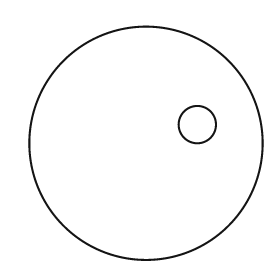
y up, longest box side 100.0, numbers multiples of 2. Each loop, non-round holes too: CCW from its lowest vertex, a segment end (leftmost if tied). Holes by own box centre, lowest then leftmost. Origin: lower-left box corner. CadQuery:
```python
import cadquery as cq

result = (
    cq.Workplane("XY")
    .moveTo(50.0, 50.0)
    .circle(50.0)
    .moveTo(72.0, 58.0)
    .circle(8.0)
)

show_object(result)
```